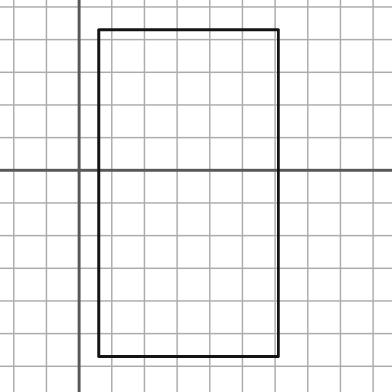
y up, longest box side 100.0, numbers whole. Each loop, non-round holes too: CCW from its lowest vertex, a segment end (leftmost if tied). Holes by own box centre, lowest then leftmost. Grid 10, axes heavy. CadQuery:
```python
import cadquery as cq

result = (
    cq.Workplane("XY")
    .moveTo(6.0, -57.0)
    .lineTo(61.0, -57.0)
    .lineTo(61.0, 43.0)
    .lineTo(6.0, 43.0)
    .close()
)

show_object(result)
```